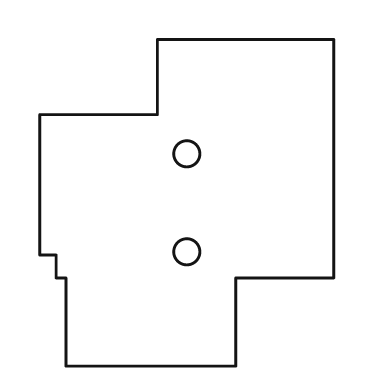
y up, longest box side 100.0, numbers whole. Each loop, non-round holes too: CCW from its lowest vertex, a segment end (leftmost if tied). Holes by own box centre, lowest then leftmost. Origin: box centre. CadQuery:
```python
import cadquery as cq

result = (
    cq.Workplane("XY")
    .moveTo(-37.0, -50.0)
    .lineTo(15.0, -50.0)
    .lineTo(15.0, -23.0)
    .lineTo(45.0, -23.0)
    .lineTo(45.0, 50.0)
    .lineTo(-9.0, 50.0)
    .lineTo(-9.0, 27.0)
    .lineTo(-45.0, 27.0)
    .lineTo(-45.0, -16.0)
    .lineTo(-40.0, -16.0)
    .lineTo(-40.0, -23.0)
    .lineTo(-37.0, -23.0)
    .close()
    .moveTo(0.0, -15.0)
    .circle(4.0)
    .moveTo(0.0, 15.0)
    .circle(4.0)
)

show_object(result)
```